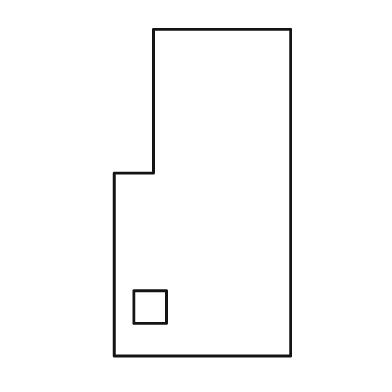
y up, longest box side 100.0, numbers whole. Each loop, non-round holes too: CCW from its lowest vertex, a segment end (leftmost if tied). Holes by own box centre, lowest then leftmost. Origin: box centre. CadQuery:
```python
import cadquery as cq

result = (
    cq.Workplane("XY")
    .moveTo(-27.0, -50.0)
    .lineTo(27.0, -50.0)
    .lineTo(27.0, 50.0)
    .lineTo(-15.0, 50.0)
    .lineTo(-15.0, 6.0)
    .lineTo(-27.0, 6.0)
    .close()
    .moveTo(-21.0, -40.0)
    .lineTo(-11.0, -40.0)
    .lineTo(-11.0, -30.0)
    .lineTo(-21.0, -30.0)
    .close()
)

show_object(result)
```